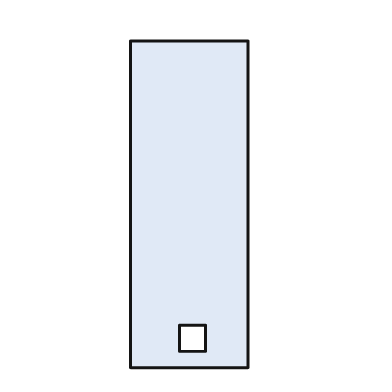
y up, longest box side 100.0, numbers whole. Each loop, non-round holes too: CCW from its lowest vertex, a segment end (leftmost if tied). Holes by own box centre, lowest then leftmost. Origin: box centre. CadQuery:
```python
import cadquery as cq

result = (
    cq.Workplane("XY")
    .moveTo(-18.0, -50.0)
    .lineTo(18.0, -50.0)
    .lineTo(18.0, 50.0)
    .lineTo(-18.0, 50.0)
    .close()
    .moveTo(-3.0, -45.0)
    .lineTo(5.0, -45.0)
    .lineTo(5.0, -37.0)
    .lineTo(-3.0, -37.0)
    .close()
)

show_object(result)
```